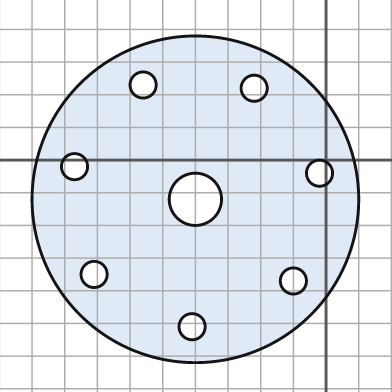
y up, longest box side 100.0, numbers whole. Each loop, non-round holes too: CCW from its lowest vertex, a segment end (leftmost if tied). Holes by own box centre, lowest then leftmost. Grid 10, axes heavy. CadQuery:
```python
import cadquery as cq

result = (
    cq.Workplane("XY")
    .moveTo(-40.0, -12.0)
    .circle(50.0)
    .moveTo(-41.0, -51.0)
    .circle(4.0)
    .moveTo(-10.0, -37.0)
    .circle(4.0)
    .moveTo(-71.0, -35.0)
    .circle(4.0)
    .moveTo(-40.0, -12.0)
    .circle(8.0)
    .moveTo(-2.0, -4.0)
    .circle(4.0)
    .moveTo(-77.0, -2.0)
    .circle(4.0)
    .moveTo(-22.0, 22.0)
    .circle(4.0)
    .moveTo(-56.0, 23.0)
    .circle(4.0)
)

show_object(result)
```